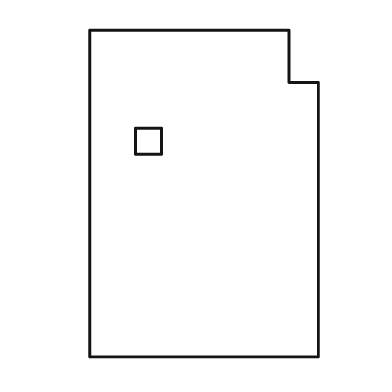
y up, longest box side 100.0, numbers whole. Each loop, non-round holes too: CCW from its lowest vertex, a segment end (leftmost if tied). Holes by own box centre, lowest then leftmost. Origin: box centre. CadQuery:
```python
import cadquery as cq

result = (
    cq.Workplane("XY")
    .moveTo(-35.0, -50.0)
    .lineTo(35.0, -50.0)
    .lineTo(35.0, 34.0)
    .lineTo(26.0, 34.0)
    .lineTo(26.0, 50.0)
    .lineTo(-35.0, 50.0)
    .close()
    .moveTo(-21.0, 12.0)
    .lineTo(-13.0, 12.0)
    .lineTo(-13.0, 20.0)
    .lineTo(-21.0, 20.0)
    .close()
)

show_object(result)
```